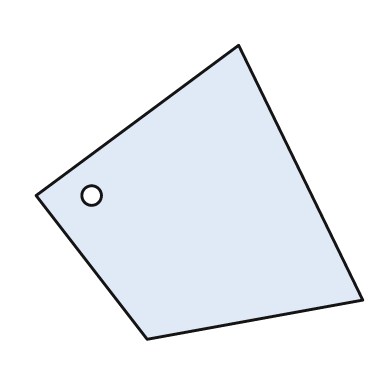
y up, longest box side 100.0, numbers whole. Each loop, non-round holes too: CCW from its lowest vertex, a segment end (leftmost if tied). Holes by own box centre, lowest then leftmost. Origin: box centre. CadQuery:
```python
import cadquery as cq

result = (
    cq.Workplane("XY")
    .moveTo(-16.0, -45.0)
    .lineTo(50.0, -33.0)
    .lineTo(12.0, 45.0)
    .lineTo(-50.0, -1.0)
    .close()
    .moveTo(-33.0, -1.0)
    .circle(3.0)
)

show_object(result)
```